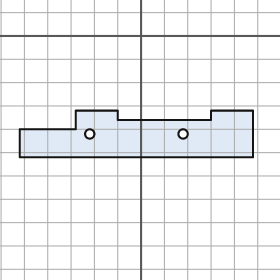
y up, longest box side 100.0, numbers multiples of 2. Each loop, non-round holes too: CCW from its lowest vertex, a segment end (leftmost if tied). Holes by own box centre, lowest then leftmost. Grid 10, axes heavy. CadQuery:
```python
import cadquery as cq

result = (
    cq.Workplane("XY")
    .moveTo(-52.0, -52.0)
    .lineTo(48.0, -52.0)
    .lineTo(48.0, -32.0)
    .lineTo(30.0, -32.0)
    .lineTo(30.0, -36.0)
    .lineTo(-10.0, -36.0)
    .lineTo(-10.0, -32.0)
    .lineTo(-28.0, -32.0)
    .lineTo(-28.0, -40.0)
    .lineTo(-52.0, -40.0)
    .close()
    .moveTo(-22.0, -42.0)
    .circle(2.0)
    .moveTo(18.0, -42.0)
    .circle(2.0)
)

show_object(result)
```